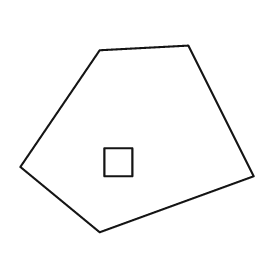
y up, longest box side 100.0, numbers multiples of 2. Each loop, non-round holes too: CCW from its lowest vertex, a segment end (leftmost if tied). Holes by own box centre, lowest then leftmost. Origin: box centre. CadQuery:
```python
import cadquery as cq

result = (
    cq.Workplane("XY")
    .moveTo(-16.0, -40.0)
    .lineTo(50.0, -16.0)
    .lineTo(22.0, 40.0)
    .lineTo(-16.0, 38.0)
    .lineTo(-50.0, -12.0)
    .close()
    .moveTo(-14.0, -16.0)
    .lineTo(-2.0, -16.0)
    .lineTo(-2.0, -4.0)
    .lineTo(-14.0, -4.0)
    .close()
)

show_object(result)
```